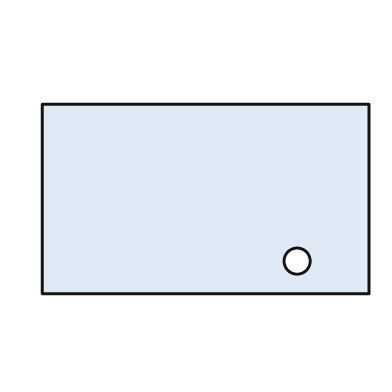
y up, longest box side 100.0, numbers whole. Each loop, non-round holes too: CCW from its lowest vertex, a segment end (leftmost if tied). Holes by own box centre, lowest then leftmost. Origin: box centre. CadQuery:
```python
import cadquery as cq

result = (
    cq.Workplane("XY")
    .moveTo(-50.0, -29.0)
    .lineTo(50.0, -29.0)
    .lineTo(50.0, 29.0)
    .lineTo(-50.0, 29.0)
    .close()
    .moveTo(28.0, -19.0)
    .circle(4.0)
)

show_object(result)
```